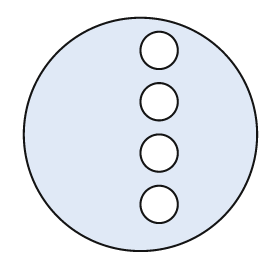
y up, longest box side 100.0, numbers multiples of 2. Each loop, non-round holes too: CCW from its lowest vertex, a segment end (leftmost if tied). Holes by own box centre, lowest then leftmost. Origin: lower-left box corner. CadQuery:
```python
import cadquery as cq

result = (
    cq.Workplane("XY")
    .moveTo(50.0, 50.0)
    .circle(50.0)
    .moveTo(58.0, 20.0)
    .circle(8.0)
    .moveTo(58.0, 42.0)
    .circle(8.0)
    .moveTo(58.0, 64.0)
    .circle(8.0)
    .moveTo(58.0, 86.0)
    .circle(8.0)
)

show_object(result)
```